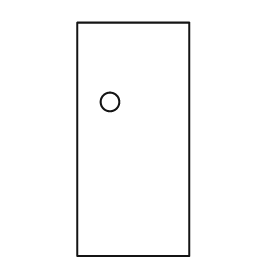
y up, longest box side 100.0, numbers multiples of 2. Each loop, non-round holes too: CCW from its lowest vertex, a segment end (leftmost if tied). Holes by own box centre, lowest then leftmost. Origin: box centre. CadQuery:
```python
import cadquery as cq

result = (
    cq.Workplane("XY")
    .moveTo(-24.0, -50.0)
    .lineTo(24.0, -50.0)
    .lineTo(24.0, 50.0)
    .lineTo(-24.0, 50.0)
    .close()
    .moveTo(-10.0, 16.0)
    .circle(4.0)
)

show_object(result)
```